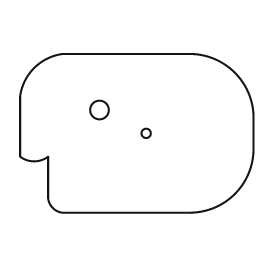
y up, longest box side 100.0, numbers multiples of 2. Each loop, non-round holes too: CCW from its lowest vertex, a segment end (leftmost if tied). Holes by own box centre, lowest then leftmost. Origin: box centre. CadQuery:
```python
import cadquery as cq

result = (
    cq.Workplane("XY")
    .moveTo(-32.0, -34.0)
    .lineTo(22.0, -34.0)
    .threePointArc((42.0, -26.0), (50.0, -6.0))
    .lineTo(50.0, 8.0)
    .threePointArc((42.0, 26.0), (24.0, 34.0))
    .lineTo(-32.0, 34.0)
    .threePointArc((-44.0, 28.0), (-50.0, 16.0))
    .lineTo(-50.0, -10.0)
    .threePointArc((-44.0, -12.0), (-38.0, -10.0))
    .lineTo(-38.0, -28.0)
    .threePointArc((-36.0, -32.0), (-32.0, -34.0))
    .close()
    .moveTo(4.0, 0.0)
    .circle(2.0)
    .moveTo(-16.0, 10.0)
    .circle(4.0)
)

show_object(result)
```